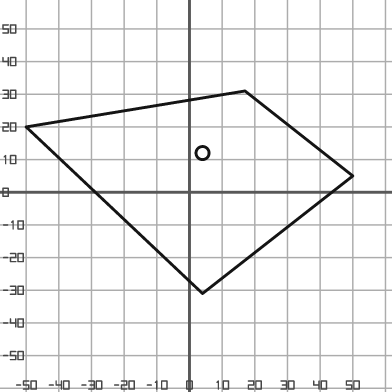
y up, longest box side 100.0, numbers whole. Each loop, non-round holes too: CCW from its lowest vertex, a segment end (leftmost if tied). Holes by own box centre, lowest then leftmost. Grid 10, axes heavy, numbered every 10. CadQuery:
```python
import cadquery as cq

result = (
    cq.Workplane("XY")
    .moveTo(4.0, -31.0)
    .lineTo(50.0, 5.0)
    .lineTo(17.0, 31.0)
    .lineTo(-50.0, 20.0)
    .close()
    .moveTo(4.0, 12.0)
    .circle(2.0)
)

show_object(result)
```